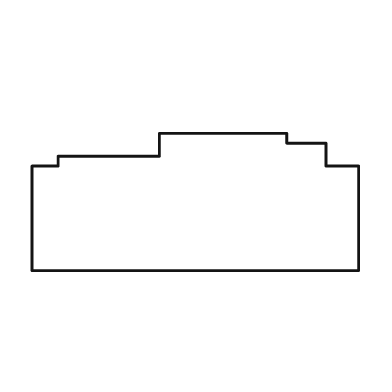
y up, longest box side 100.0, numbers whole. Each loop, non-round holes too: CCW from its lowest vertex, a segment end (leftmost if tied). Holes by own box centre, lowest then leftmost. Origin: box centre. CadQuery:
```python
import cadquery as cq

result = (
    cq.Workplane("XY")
    .moveTo(-50.0, -21.0)
    .lineTo(50.0, -21.0)
    .lineTo(50.0, 11.0)
    .lineTo(40.0, 11.0)
    .lineTo(40.0, 18.0)
    .lineTo(28.0, 18.0)
    .lineTo(28.0, 21.0)
    .lineTo(-11.0, 21.0)
    .lineTo(-11.0, 14.0)
    .lineTo(-42.0, 14.0)
    .lineTo(-42.0, 11.0)
    .lineTo(-50.0, 11.0)
    .close()
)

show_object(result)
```